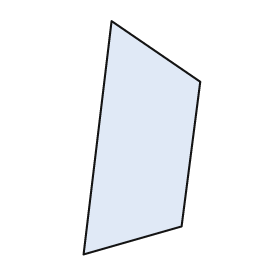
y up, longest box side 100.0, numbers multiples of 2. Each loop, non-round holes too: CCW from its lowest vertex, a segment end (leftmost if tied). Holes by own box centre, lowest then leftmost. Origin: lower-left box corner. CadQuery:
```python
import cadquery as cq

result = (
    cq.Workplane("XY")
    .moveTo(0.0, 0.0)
    .lineTo(42.0, 12.0)
    .lineTo(50.0, 74.0)
    .lineTo(12.0, 100.0)
    .close()
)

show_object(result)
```